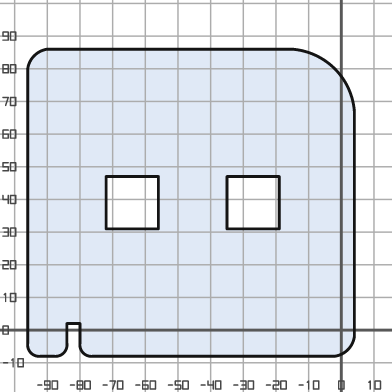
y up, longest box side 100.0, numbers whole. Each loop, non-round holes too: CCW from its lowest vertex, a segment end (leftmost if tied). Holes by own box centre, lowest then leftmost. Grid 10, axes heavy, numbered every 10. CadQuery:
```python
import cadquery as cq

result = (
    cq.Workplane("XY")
    .moveTo(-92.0, -8.0)
    .lineTo(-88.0, -8.0)
    .threePointArc((-85.0, -7.0), (-84.0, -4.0))
    .lineTo(-84.0, 2.0)
    .lineTo(-80.0, 2.0)
    .lineTo(-80.0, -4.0)
    .threePointArc((-79.0, -7.0), (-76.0, -8.0))
    .lineTo(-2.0, -8.0)
    .threePointArc((2.0, -6.0), (4.0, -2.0))
    .lineTo(4.0, 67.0)
    .threePointArc((-2.0, 80.0), (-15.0, 86.0))
    .lineTo(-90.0, 86.0)
    .threePointArc((-94.0, 84.0), (-96.0, 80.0))
    .lineTo(-96.0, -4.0)
    .threePointArc((-95.0, -7.0), (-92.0, -8.0))
    .close()
    .moveTo(-72.0, 31.0)
    .lineTo(-56.0, 31.0)
    .lineTo(-56.0, 47.0)
    .lineTo(-72.0, 47.0)
    .close()
    .moveTo(-35.0, 31.0)
    .lineTo(-19.0, 31.0)
    .lineTo(-19.0, 47.0)
    .lineTo(-35.0, 47.0)
    .close()
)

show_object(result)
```